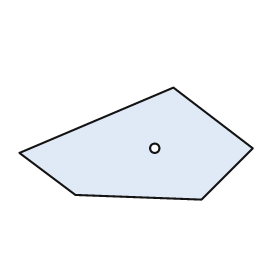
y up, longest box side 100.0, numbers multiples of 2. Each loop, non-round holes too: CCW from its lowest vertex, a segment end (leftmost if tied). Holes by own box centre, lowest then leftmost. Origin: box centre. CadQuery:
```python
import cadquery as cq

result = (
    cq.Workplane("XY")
    .moveTo(28.0, -24.0)
    .lineTo(50.0, -2.0)
    .lineTo(16.0, 24.0)
    .lineTo(-50.0, -4.0)
    .lineTo(-26.0, -22.0)
    .close()
    .moveTo(8.0, -2.0)
    .circle(2.0)
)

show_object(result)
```